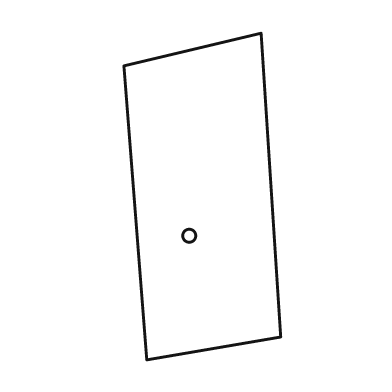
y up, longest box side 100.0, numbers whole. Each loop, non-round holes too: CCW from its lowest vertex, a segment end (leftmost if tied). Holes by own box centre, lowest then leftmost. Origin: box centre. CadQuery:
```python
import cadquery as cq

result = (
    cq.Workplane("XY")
    .moveTo(-17.0, -50.0)
    .lineTo(24.0, -43.0)
    .lineTo(18.0, 50.0)
    .lineTo(-24.0, 40.0)
    .close()
    .moveTo(-4.0, -12.0)
    .circle(2.0)
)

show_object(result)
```